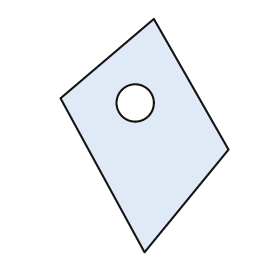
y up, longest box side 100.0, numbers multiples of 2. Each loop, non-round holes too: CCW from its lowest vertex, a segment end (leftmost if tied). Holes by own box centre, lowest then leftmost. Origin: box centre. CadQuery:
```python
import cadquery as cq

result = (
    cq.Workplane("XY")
    .moveTo(0.0, -50.0)
    .lineTo(36.0, -6.0)
    .lineTo(4.0, 50.0)
    .lineTo(-36.0, 16.0)
    .close()
    .moveTo(-4.0, 14.0)
    .circle(8.0)
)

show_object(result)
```